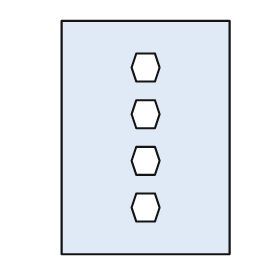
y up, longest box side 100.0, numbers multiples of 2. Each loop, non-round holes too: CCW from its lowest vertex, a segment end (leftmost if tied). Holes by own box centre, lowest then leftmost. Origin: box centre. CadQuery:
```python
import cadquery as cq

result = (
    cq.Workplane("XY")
    .moveTo(-36.0, -50.0)
    .lineTo(36.0, -50.0)
    .lineTo(36.0, 50.0)
    .lineTo(-36.0, 50.0)
    .close()
    .moveTo(-4.0, -36.0)
    .lineTo(4.0, -36.0)
    .lineTo(6.0, -30.0)
    .lineTo(4.0, -24.0)
    .lineTo(-4.0, -24.0)
    .lineTo(-6.0, -30.0)
    .close()
    .moveTo(-4.0, -16.0)
    .lineTo(4.0, -16.0)
    .lineTo(6.0, -10.0)
    .lineTo(4.0, -4.0)
    .lineTo(-4.0, -4.0)
    .lineTo(-6.0, -10.0)
    .close()
    .moveTo(-4.0, 4.0)
    .lineTo(4.0, 4.0)
    .lineTo(6.0, 10.0)
    .lineTo(4.0, 16.0)
    .lineTo(-4.0, 16.0)
    .lineTo(-6.0, 10.0)
    .close()
    .moveTo(-4.0, 24.0)
    .lineTo(4.0, 24.0)
    .lineTo(6.0, 30.0)
    .lineTo(4.0, 36.0)
    .lineTo(-4.0, 36.0)
    .lineTo(-6.0, 30.0)
    .close()
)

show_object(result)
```